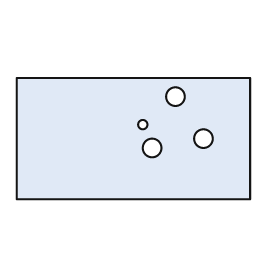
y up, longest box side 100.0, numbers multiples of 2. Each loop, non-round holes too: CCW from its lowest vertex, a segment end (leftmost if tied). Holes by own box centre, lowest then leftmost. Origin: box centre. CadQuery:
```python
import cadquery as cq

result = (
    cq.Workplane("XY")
    .moveTo(-50.0, -26.0)
    .lineTo(50.0, -26.0)
    .lineTo(50.0, 26.0)
    .lineTo(-50.0, 26.0)
    .close()
    .moveTo(8.0, -4.0)
    .circle(4.0)
    .moveTo(30.0, 0.0)
    .circle(4.0)
    .moveTo(4.0, 6.0)
    .circle(2.0)
    .moveTo(18.0, 18.0)
    .circle(4.0)
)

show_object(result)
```